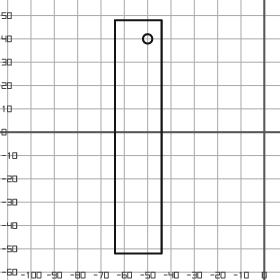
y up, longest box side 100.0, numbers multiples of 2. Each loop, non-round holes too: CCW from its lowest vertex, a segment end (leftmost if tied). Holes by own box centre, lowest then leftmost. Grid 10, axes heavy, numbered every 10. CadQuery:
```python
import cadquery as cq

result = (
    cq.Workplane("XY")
    .moveTo(-64.0, -52.0)
    .lineTo(-44.0, -52.0)
    .lineTo(-44.0, 48.0)
    .lineTo(-64.0, 48.0)
    .close()
    .moveTo(-50.0, 40.0)
    .circle(2.0)
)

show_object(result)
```